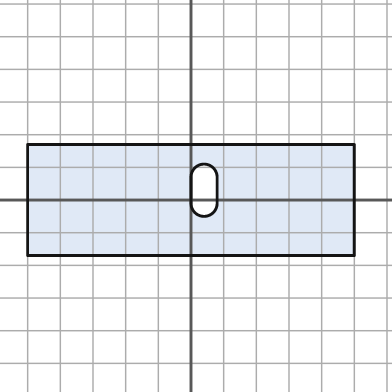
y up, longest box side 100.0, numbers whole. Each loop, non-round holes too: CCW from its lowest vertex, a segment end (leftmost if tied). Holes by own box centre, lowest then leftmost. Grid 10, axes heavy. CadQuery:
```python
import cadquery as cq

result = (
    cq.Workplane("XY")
    .moveTo(-50.0, -17.0)
    .lineTo(50.0, -17.0)
    .lineTo(50.0, 17.0)
    .lineTo(-50.0, 17.0)
    .close()
    .moveTo(0.0, -1.0)
    .threePointArc((4.0, -5.0), (8.0, -1.0))
    .lineTo(8.0, 7.0)
    .threePointArc((4.0, 11.0), (0.0, 7.0))
    .close()
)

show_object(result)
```